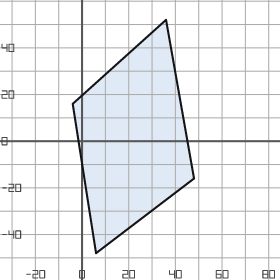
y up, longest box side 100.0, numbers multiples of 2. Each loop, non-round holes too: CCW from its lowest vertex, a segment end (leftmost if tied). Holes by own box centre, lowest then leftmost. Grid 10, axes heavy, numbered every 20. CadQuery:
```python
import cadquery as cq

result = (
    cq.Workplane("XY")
    .moveTo(6.0, -48.0)
    .lineTo(48.0, -16.0)
    .lineTo(36.0, 52.0)
    .lineTo(-4.0, 16.0)
    .close()
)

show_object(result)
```